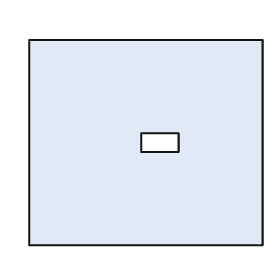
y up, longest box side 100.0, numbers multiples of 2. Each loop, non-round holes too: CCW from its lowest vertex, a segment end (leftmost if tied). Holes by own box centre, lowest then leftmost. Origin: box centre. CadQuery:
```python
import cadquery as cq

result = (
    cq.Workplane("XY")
    .moveTo(-50.0, -44.0)
    .lineTo(50.0, -44.0)
    .lineTo(50.0, 44.0)
    .lineTo(-50.0, 44.0)
    .close()
    .moveTo(-2.0, -4.0)
    .lineTo(14.0, -4.0)
    .lineTo(14.0, 4.0)
    .lineTo(-2.0, 4.0)
    .close()
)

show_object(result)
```